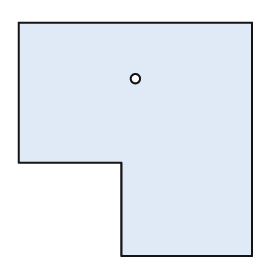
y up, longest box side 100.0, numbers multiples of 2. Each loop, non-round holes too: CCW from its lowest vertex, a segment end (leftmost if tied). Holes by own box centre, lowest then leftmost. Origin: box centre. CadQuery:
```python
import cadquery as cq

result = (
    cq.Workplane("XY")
    .moveTo(-6.0, -50.0)
    .lineTo(50.0, -50.0)
    .lineTo(50.0, 50.0)
    .lineTo(-50.0, 50.0)
    .lineTo(-50.0, -10.0)
    .lineTo(-6.0, -10.0)
    .close()
    .moveTo(0.0, 26.0)
    .circle(2.0)
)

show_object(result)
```